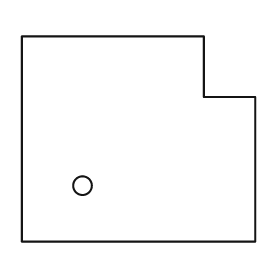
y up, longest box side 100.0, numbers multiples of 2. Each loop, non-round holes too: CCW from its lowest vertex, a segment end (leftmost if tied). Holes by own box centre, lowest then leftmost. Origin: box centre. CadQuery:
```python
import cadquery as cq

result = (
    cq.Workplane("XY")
    .moveTo(-50.0, -44.0)
    .lineTo(50.0, -44.0)
    .lineTo(50.0, 18.0)
    .lineTo(28.0, 18.0)
    .lineTo(28.0, 44.0)
    .lineTo(-50.0, 44.0)
    .close()
    .moveTo(-24.0, -20.0)
    .circle(4.0)
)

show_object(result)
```